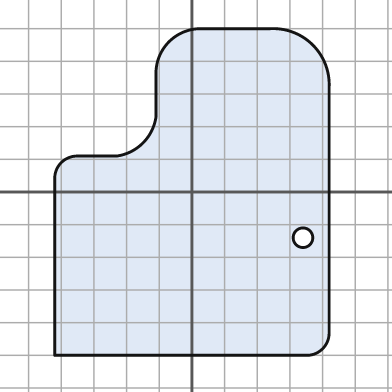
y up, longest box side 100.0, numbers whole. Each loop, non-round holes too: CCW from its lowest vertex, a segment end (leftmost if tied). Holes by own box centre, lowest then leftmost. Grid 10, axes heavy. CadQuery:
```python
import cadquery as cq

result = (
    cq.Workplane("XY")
    .moveTo(-42.0, -50.0)
    .lineTo(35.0, -50.0)
    .threePointArc((40.0, -48.0), (42.0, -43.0))
    .lineTo(42.0, 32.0)
    .threePointArc((37.0, 45.0), (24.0, 50.0))
    .lineTo(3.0, 50.0)
    .threePointArc((-7.0, 46.0), (-11.0, 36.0))
    .lineTo(-11.0, 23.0)
    .threePointArc((-15.0, 15.0), (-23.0, 11.0))
    .lineTo(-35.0, 11.0)
    .threePointArc((-40.0, 9.0), (-42.0, 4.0))
    .close()
    .moveTo(34.0, -14.0)
    .circle(3.0)
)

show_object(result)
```